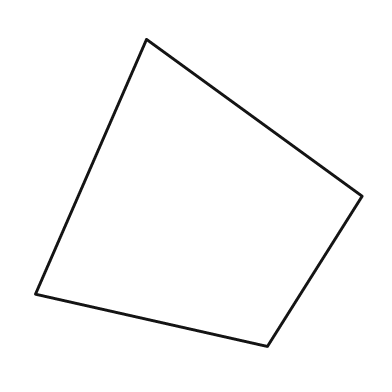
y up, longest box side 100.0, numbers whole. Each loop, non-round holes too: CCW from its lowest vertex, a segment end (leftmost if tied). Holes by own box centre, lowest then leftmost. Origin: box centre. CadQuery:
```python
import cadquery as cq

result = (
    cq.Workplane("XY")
    .moveTo(21.0, -47.0)
    .lineTo(50.0, -1.0)
    .lineTo(-16.0, 47.0)
    .lineTo(-50.0, -31.0)
    .close()
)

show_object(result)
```